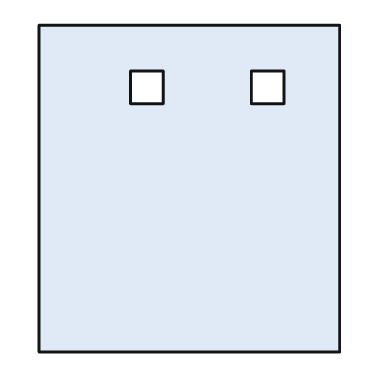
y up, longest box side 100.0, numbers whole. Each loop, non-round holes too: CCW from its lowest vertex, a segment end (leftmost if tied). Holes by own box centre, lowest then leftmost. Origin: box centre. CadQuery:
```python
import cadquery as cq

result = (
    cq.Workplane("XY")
    .moveTo(-46.0, -50.0)
    .lineTo(46.0, -50.0)
    .lineTo(46.0, 50.0)
    .lineTo(-46.0, 50.0)
    .close()
    .moveTo(-18.0, 26.0)
    .lineTo(-8.0, 26.0)
    .lineTo(-8.0, 36.0)
    .lineTo(-18.0, 36.0)
    .close()
    .moveTo(19.0, 26.0)
    .lineTo(29.0, 26.0)
    .lineTo(29.0, 36.0)
    .lineTo(19.0, 36.0)
    .close()
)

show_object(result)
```